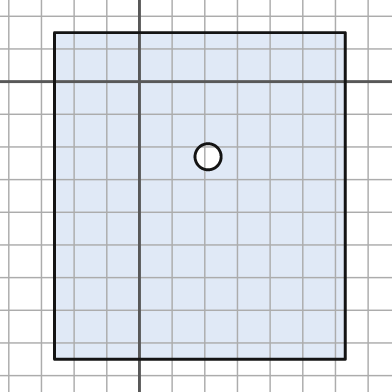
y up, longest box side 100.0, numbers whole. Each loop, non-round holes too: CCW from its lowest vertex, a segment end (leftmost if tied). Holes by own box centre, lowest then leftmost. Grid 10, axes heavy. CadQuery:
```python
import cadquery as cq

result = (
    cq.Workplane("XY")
    .moveTo(-26.0, -85.0)
    .lineTo(63.0, -85.0)
    .lineTo(63.0, 15.0)
    .lineTo(-26.0, 15.0)
    .close()
    .moveTo(21.0, -23.0)
    .circle(4.0)
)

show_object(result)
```